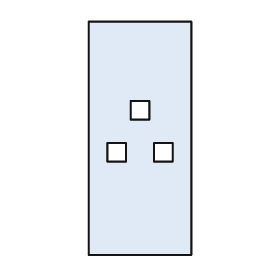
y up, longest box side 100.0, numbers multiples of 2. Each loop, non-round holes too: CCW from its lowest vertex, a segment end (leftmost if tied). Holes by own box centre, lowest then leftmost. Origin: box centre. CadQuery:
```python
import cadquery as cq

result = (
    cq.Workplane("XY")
    .moveTo(-22.0, -50.0)
    .lineTo(22.0, -50.0)
    .lineTo(22.0, 50.0)
    .lineTo(-22.0, 50.0)
    .close()
    .moveTo(-14.0, -10.0)
    .lineTo(-6.0, -10.0)
    .lineTo(-6.0, -2.0)
    .lineTo(-14.0, -2.0)
    .close()
    .moveTo(6.0, -10.0)
    .lineTo(14.0, -10.0)
    .lineTo(14.0, -2.0)
    .lineTo(6.0, -2.0)
    .close()
    .moveTo(-4.0, 8.0)
    .lineTo(4.0, 8.0)
    .lineTo(4.0, 16.0)
    .lineTo(-4.0, 16.0)
    .close()
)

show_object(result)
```